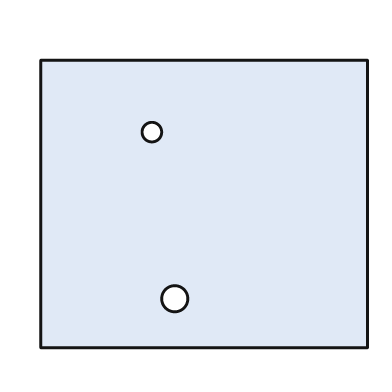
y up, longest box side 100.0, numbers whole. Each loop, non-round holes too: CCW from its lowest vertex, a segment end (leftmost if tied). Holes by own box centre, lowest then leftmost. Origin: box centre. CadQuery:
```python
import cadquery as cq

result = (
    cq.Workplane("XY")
    .moveTo(-50.0, -44.0)
    .lineTo(50.0, -44.0)
    .lineTo(50.0, 44.0)
    .lineTo(-50.0, 44.0)
    .close()
    .moveTo(-9.0, -29.0)
    .circle(4.0)
    .moveTo(-16.0, 22.0)
    .circle(3.0)
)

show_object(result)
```